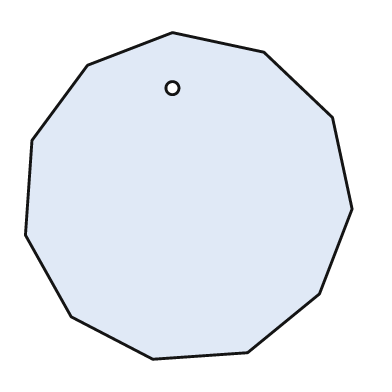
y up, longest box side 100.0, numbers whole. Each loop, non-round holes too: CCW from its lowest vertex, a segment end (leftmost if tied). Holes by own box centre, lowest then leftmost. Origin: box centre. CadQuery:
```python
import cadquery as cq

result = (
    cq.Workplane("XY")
    .moveTo(-11.0, -50.0)
    .lineTo(18.0, -48.0)
    .lineTo(40.0, -30.0)
    .lineTo(50.0, -4.0)
    .lineTo(44.0, 24.0)
    .lineTo(23.0, 44.0)
    .lineTo(-5.0, 50.0)
    .lineTo(-31.0, 40.0)
    .lineTo(-48.0, 17.0)
    .lineTo(-50.0, -12.0)
    .lineTo(-36.0, -37.0)
    .close()
    .moveTo(-5.0, 33.0)
    .circle(2.0)
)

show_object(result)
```